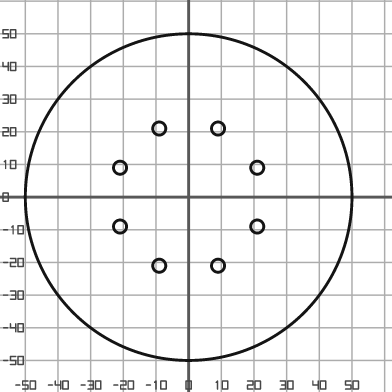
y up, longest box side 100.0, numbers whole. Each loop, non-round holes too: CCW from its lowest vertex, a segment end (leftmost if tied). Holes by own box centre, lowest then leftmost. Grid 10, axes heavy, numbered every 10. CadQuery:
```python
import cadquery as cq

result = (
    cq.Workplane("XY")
    .moveTo(0.0, 0.0)
    .circle(50.0)
    .moveTo(-9.0, -21.0)
    .circle(2.0)
    .moveTo(9.0, -21.0)
    .circle(2.0)
    .moveTo(-21.0, -9.0)
    .circle(2.0)
    .moveTo(21.0, -9.0)
    .circle(2.0)
    .moveTo(-21.0, 9.0)
    .circle(2.0)
    .moveTo(21.0, 9.0)
    .circle(2.0)
    .moveTo(-9.0, 21.0)
    .circle(2.0)
    .moveTo(9.0, 21.0)
    .circle(2.0)
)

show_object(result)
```